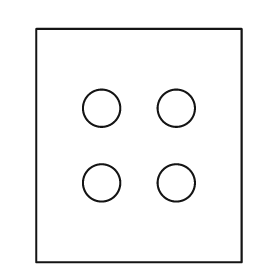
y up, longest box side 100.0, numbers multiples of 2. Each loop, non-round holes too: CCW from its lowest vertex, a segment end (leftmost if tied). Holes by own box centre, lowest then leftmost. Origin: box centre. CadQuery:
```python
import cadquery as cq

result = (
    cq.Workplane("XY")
    .moveTo(-44.0, -50.0)
    .lineTo(44.0, -50.0)
    .lineTo(44.0, 50.0)
    .lineTo(-44.0, 50.0)
    .close()
    .moveTo(-16.0, -16.0)
    .circle(8.0)
    .moveTo(16.0, -16.0)
    .circle(8.0)
    .moveTo(-16.0, 16.0)
    .circle(8.0)
    .moveTo(16.0, 16.0)
    .circle(8.0)
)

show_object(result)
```